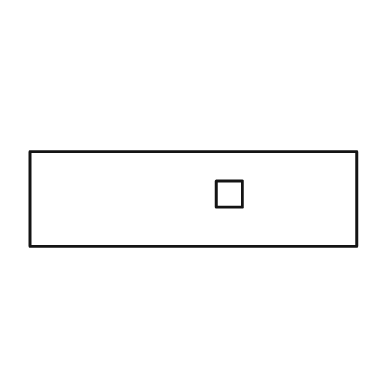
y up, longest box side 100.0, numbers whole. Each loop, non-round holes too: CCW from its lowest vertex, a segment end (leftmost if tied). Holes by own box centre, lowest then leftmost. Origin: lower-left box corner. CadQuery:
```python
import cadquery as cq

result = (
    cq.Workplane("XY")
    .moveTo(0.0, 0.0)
    .lineTo(100.0, 0.0)
    .lineTo(100.0, 29.0)
    .lineTo(0.0, 29.0)
    .close()
    .moveTo(57.0, 12.0)
    .lineTo(65.0, 12.0)
    .lineTo(65.0, 20.0)
    .lineTo(57.0, 20.0)
    .close()
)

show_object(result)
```